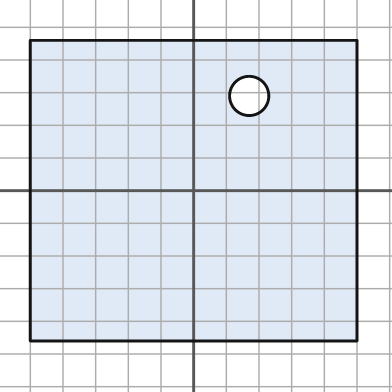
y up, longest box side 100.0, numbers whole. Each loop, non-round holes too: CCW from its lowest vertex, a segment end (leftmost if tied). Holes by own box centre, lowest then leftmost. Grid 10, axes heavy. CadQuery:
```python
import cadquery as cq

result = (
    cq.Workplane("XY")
    .moveTo(-50.0, -46.0)
    .lineTo(50.0, -46.0)
    .lineTo(50.0, 46.0)
    .lineTo(-50.0, 46.0)
    .close()
    .moveTo(17.0, 29.0)
    .circle(6.0)
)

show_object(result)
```